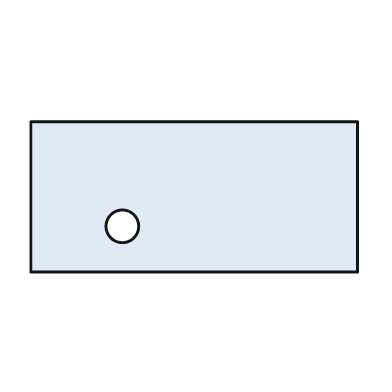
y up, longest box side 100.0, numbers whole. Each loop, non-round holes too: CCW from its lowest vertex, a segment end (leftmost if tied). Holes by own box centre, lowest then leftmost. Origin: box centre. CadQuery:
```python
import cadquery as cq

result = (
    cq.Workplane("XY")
    .moveTo(-50.0, -23.0)
    .lineTo(50.0, -23.0)
    .lineTo(50.0, 23.0)
    .lineTo(-50.0, 23.0)
    .close()
    .moveTo(-22.0, -9.0)
    .circle(5.0)
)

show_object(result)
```